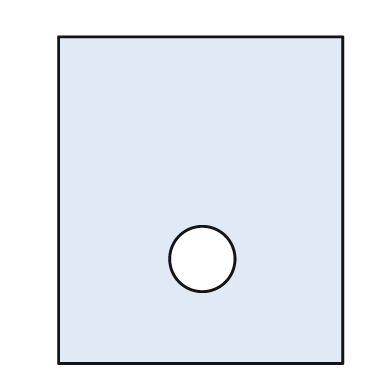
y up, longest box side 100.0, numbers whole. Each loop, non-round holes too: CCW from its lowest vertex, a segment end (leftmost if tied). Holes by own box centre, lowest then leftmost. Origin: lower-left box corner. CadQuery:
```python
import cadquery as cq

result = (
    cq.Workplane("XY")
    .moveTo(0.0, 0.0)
    .lineTo(87.0, 0.0)
    .lineTo(87.0, 100.0)
    .lineTo(0.0, 100.0)
    .close()
    .moveTo(44.0, 32.0)
    .circle(10.0)
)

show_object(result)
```